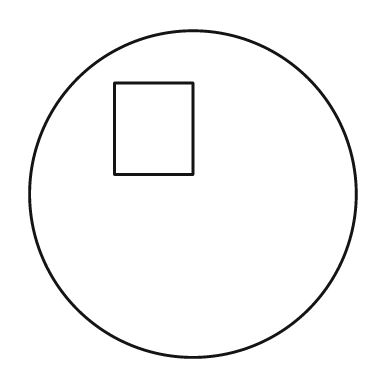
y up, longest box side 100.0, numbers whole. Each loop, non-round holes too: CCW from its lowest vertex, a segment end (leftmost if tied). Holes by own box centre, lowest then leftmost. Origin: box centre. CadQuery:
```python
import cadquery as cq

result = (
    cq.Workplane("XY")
    .moveTo(0.0, 0.0)
    .circle(50.0)
    .moveTo(-24.0, 6.0)
    .lineTo(0.0, 6.0)
    .lineTo(0.0, 34.0)
    .lineTo(-24.0, 34.0)
    .close()
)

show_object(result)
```